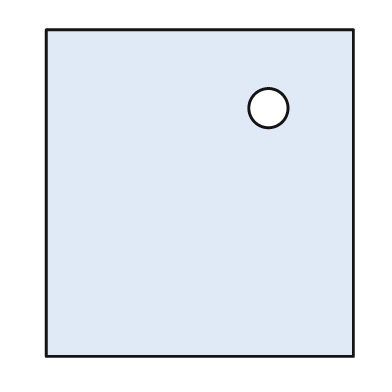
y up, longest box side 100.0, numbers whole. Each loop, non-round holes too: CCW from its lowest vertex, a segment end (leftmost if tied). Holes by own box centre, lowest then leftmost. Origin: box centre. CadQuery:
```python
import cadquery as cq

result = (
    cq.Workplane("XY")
    .moveTo(-47.0, -50.0)
    .lineTo(47.0, -50.0)
    .lineTo(47.0, 50.0)
    .lineTo(-47.0, 50.0)
    .close()
    .moveTo(21.0, 26.0)
    .circle(6.0)
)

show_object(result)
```